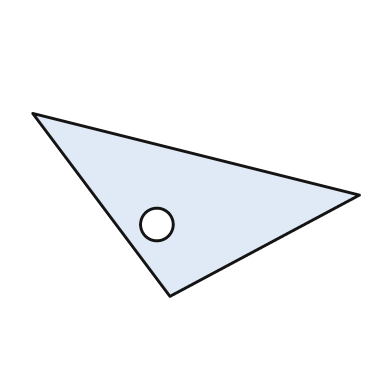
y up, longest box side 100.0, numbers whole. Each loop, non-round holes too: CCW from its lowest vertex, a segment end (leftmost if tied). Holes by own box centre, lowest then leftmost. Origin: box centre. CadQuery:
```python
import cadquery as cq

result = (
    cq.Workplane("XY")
    .moveTo(-8.0, -28.0)
    .lineTo(50.0, 3.0)
    .lineTo(-50.0, 28.0)
    .close()
    .moveTo(-12.0, -6.0)
    .circle(5.0)
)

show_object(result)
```